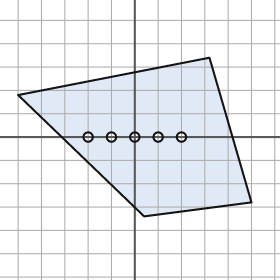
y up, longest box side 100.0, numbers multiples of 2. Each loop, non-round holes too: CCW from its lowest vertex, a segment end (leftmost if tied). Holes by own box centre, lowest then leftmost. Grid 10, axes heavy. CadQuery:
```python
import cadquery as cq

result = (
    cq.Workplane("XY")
    .moveTo(4.0, -34.0)
    .lineTo(50.0, -28.0)
    .lineTo(32.0, 34.0)
    .lineTo(-50.0, 18.0)
    .close()
    .moveTo(-20.0, 0.0)
    .circle(2.0)
    .moveTo(-10.0, 0.0)
    .circle(2.0)
    .moveTo(0.0, 0.0)
    .circle(2.0)
    .moveTo(10.0, 0.0)
    .circle(2.0)
    .moveTo(20.0, 0.0)
    .circle(2.0)
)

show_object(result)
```